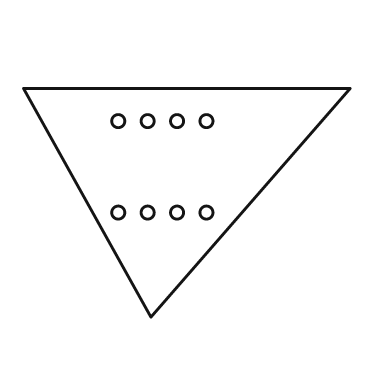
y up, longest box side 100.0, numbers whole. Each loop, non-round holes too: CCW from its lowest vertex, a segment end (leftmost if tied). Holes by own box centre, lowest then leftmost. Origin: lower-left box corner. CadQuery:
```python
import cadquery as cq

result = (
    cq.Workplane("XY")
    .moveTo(39.0, 0.0)
    .lineTo(100.0, 70.0)
    .lineTo(0.0, 70.0)
    .close()
    .moveTo(29.0, 32.0)
    .circle(2.0)
    .moveTo(38.0, 32.0)
    .circle(2.0)
    .moveTo(47.0, 32.0)
    .circle(2.0)
    .moveTo(56.0, 32.0)
    .circle(2.0)
    .moveTo(29.0, 60.0)
    .circle(2.0)
    .moveTo(38.0, 60.0)
    .circle(2.0)
    .moveTo(47.0, 60.0)
    .circle(2.0)
    .moveTo(56.0, 60.0)
    .circle(2.0)
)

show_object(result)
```